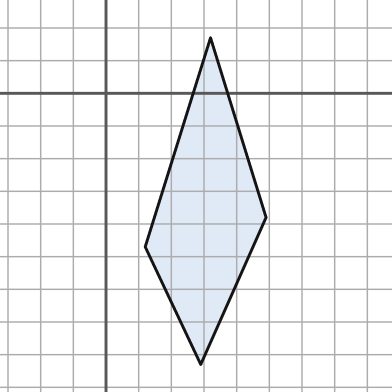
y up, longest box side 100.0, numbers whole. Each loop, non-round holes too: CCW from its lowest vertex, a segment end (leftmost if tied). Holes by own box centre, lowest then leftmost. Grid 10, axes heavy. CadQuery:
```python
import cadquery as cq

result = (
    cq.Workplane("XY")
    .moveTo(29.0, -83.0)
    .lineTo(49.0, -38.0)
    .lineTo(32.0, 17.0)
    .lineTo(12.0, -47.0)
    .close()
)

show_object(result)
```